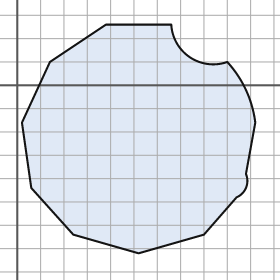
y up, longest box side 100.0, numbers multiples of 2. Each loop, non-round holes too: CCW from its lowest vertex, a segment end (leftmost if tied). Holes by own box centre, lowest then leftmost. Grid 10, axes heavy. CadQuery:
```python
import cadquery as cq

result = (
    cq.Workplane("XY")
    .moveTo(52.0, -72.0)
    .lineTo(80.0, -64.0)
    .lineTo(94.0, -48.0)
    .threePointArc((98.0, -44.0), (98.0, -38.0))
    .lineTo(102.0, -16.0)
    .threePointArc((98.0, -2.0), (90.0, 10.0))
    .threePointArc((74.0, 12.0), (66.0, 26.0))
    .lineTo(38.0, 26.0)
    .lineTo(14.0, 10.0)
    .lineTo(2.0, -16.0)
    .lineTo(6.0, -44.0)
    .lineTo(24.0, -64.0)
    .close()
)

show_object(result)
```